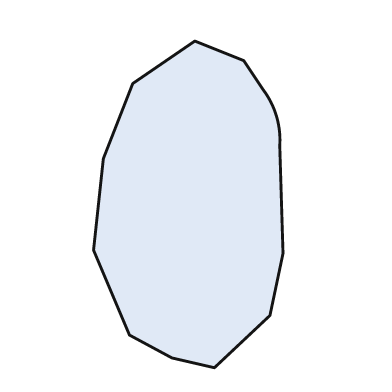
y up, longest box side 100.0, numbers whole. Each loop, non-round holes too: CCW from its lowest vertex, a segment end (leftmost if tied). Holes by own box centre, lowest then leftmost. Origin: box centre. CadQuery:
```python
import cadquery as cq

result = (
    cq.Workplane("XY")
    .moveTo(8.0, -50.0)
    .lineTo(25.0, -34.0)
    .lineTo(29.0, -15.0)
    .lineTo(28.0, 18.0)
    .threePointArc((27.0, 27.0), (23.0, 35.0))
    .lineTo(17.0, 44.0)
    .lineTo(2.0, 50.0)
    .lineTo(-17.0, 37.0)
    .lineTo(-26.0, 14.0)
    .lineTo(-29.0, -14.0)
    .lineTo(-18.0, -40.0)
    .lineTo(-5.0, -47.0)
    .close()
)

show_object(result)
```